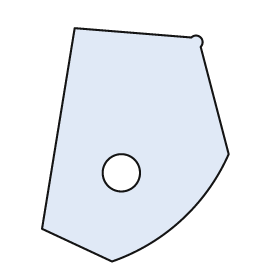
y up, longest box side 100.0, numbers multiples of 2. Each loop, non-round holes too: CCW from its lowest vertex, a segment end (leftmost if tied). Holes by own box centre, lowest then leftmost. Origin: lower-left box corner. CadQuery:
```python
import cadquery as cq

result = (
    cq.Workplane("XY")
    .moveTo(30.0, 0.0)
    .threePointArc((60.0, 18.0), (80.0, 46.0))
    .lineTo(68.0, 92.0)
    .threePointArc((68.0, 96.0), (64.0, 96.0))
    .lineTo(14.0, 100.0)
    .lineTo(0.0, 14.0)
    .close()
    .moveTo(34.0, 38.0)
    .circle(8.0)
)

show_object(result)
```